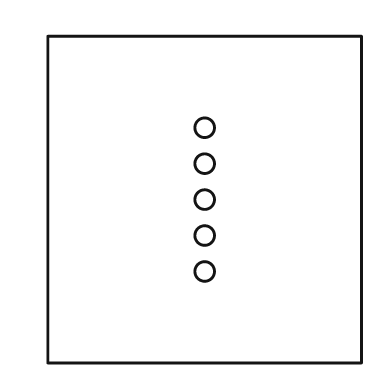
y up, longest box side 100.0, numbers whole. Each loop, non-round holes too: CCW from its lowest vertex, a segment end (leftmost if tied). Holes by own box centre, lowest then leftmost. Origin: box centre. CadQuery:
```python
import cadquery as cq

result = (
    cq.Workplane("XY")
    .moveTo(-48.0, -50.0)
    .lineTo(48.0, -50.0)
    .lineTo(48.0, 50.0)
    .lineTo(-48.0, 50.0)
    .close()
    .moveTo(0.0, -22.0)
    .circle(3.0)
    .moveTo(0.0, -11.0)
    .circle(3.0)
    .moveTo(0.0, 0.0)
    .circle(3.0)
    .moveTo(0.0, 11.0)
    .circle(3.0)
    .moveTo(0.0, 22.0)
    .circle(3.0)
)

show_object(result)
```